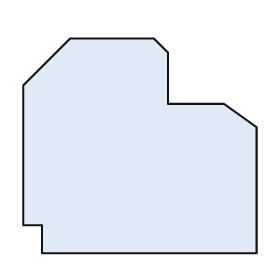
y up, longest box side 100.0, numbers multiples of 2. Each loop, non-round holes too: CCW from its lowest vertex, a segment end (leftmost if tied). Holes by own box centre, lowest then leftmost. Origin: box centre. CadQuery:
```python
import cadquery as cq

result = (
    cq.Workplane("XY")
    .moveTo(-42.0, -46.0)
    .lineTo(50.0, -46.0)
    .lineTo(50.0, 8.0)
    .lineTo(36.0, 18.0)
    .lineTo(12.0, 18.0)
    .lineTo(12.0, 40.0)
    .lineTo(6.0, 46.0)
    .lineTo(-30.0, 46.0)
    .lineTo(-50.0, 26.0)
    .lineTo(-50.0, -34.0)
    .lineTo(-42.0, -34.0)
    .close()
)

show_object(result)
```